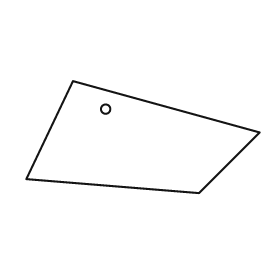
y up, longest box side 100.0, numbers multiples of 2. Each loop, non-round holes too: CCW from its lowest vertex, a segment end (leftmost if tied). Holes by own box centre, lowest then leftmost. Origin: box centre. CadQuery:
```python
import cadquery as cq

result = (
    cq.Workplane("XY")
    .moveTo(24.0, -24.0)
    .lineTo(50.0, 2.0)
    .lineTo(-30.0, 24.0)
    .lineTo(-50.0, -18.0)
    .close()
    .moveTo(-16.0, 12.0)
    .circle(2.0)
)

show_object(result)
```